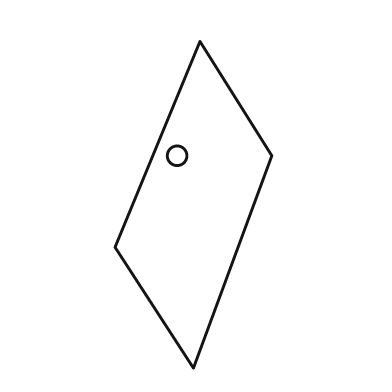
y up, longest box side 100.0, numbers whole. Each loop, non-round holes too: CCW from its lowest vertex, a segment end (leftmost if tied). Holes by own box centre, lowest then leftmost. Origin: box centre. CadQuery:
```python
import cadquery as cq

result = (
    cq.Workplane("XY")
    .moveTo(0.0, -50.0)
    .lineTo(24.0, 15.0)
    .lineTo(2.0, 50.0)
    .lineTo(-24.0, -13.0)
    .close()
    .moveTo(-5.0, 15.0)
    .circle(3.0)
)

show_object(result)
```